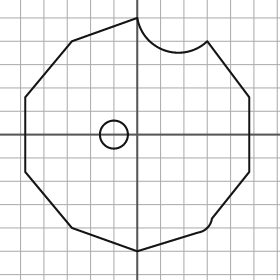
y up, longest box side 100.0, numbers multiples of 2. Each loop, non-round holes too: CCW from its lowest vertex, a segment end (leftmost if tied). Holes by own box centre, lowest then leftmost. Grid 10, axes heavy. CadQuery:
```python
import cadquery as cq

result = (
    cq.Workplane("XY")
    .moveTo(0.0, -50.0)
    .lineTo(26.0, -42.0)
    .threePointArc((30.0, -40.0), (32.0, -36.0))
    .lineTo(48.0, -16.0)
    .lineTo(48.0, 16.0)
    .lineTo(30.0, 40.0)
    .threePointArc((12.0, 36.0), (0.0, 50.0))
    .lineTo(-28.0, 40.0)
    .lineTo(-48.0, 16.0)
    .lineTo(-48.0, -16.0)
    .lineTo(-28.0, -40.0)
    .close()
    .moveTo(-10.0, 0.0)
    .circle(6.0)
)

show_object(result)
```